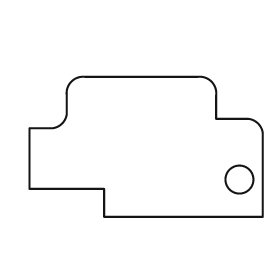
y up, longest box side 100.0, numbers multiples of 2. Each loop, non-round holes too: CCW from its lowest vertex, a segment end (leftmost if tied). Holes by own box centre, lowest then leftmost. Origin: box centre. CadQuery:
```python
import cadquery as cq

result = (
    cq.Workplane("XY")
    .moveTo(-18.0, -30.0)
    .lineTo(50.0, -30.0)
    .lineTo(50.0, 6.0)
    .threePointArc((48.0, 10.0), (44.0, 12.0))
    .lineTo(30.0, 12.0)
    .lineTo(30.0, 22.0)
    .threePointArc((28.0, 28.0), (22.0, 30.0))
    .lineTo(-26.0, 30.0)
    .threePointArc((-32.0, 28.0), (-34.0, 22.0))
    .lineTo(-34.0, 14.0)
    .threePointArc((-36.0, 10.0), (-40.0, 8.0))
    .lineTo(-50.0, 8.0)
    .lineTo(-50.0, -18.0)
    .lineTo(-18.0, -18.0)
    .close()
    .moveTo(40.0, -14.0)
    .circle(6.0)
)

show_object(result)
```